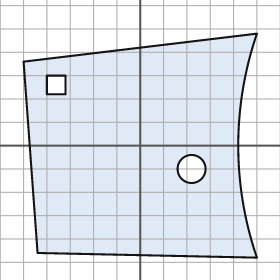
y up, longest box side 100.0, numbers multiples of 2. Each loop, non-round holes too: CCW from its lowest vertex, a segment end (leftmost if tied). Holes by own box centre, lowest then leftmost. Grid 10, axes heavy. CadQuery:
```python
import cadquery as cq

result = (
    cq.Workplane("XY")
    .moveTo(50.0, -48.0)
    .threePointArc((42.0, 0.0), (50.0, 48.0))
    .lineTo(-50.0, 36.0)
    .lineTo(-44.0, -46.0)
    .close()
    .moveTo(22.0, -10.0)
    .circle(6.0)
    .moveTo(-40.0, 22.0)
    .lineTo(-32.0, 22.0)
    .lineTo(-32.0, 30.0)
    .lineTo(-40.0, 30.0)
    .close()
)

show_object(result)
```